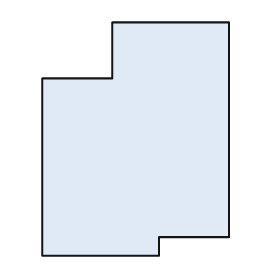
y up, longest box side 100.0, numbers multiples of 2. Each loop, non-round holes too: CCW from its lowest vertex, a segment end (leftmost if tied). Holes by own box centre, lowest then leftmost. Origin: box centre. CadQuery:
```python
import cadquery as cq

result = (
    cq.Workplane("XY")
    .moveTo(-40.0, -50.0)
    .lineTo(10.0, -50.0)
    .lineTo(10.0, -42.0)
    .lineTo(40.0, -42.0)
    .lineTo(40.0, 50.0)
    .lineTo(-10.0, 50.0)
    .lineTo(-10.0, 26.0)
    .lineTo(-40.0, 26.0)
    .close()
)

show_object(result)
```